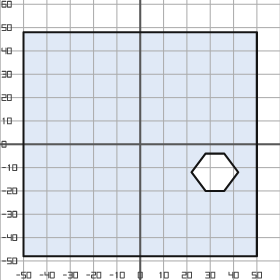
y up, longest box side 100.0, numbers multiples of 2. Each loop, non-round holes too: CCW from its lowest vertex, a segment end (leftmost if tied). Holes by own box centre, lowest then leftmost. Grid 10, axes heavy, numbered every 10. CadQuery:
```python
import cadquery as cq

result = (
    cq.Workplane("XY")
    .moveTo(-50.0, -48.0)
    .lineTo(50.0, -48.0)
    .lineTo(50.0, 48.0)
    .lineTo(-50.0, 48.0)
    .close()
    .moveTo(28.0, -20.0)
    .lineTo(36.0, -20.0)
    .lineTo(42.0, -12.0)
    .lineTo(36.0, -4.0)
    .lineTo(28.0, -4.0)
    .lineTo(22.0, -12.0)
    .close()
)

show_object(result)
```